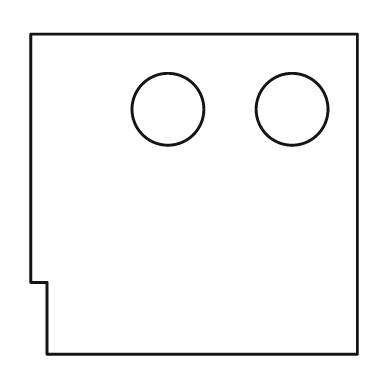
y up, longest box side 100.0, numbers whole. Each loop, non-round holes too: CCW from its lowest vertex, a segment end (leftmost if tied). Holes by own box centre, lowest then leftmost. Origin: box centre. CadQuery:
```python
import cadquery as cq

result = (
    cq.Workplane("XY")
    .moveTo(-45.0, -49.0)
    .lineTo(50.0, -49.0)
    .lineTo(50.0, 49.0)
    .lineTo(-50.0, 49.0)
    .lineTo(-50.0, -27.0)
    .lineTo(-45.0, -27.0)
    .close()
    .moveTo(-8.0, 26.0)
    .circle(11.0)
    .moveTo(30.0, 26.0)
    .circle(11.0)
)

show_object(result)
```